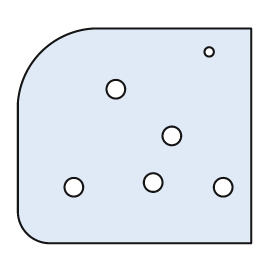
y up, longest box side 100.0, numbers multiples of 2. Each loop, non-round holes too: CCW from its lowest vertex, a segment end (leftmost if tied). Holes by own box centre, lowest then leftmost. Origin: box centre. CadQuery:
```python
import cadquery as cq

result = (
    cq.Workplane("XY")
    .moveTo(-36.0, -46.0)
    .lineTo(50.0, -46.0)
    .lineTo(50.0, 46.0)
    .lineTo(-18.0, 46.0)
    .threePointArc((-40.0, 36.0), (-50.0, 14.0))
    .lineTo(-50.0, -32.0)
    .threePointArc((-46.0, -42.0), (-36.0, -46.0))
    .close()
    .moveTo(-26.0, -22.0)
    .circle(4.0)
    .moveTo(38.0, -22.0)
    .circle(4.0)
    .moveTo(8.0, -20.0)
    .circle(4.0)
    .moveTo(16.0, 0.0)
    .circle(4.0)
    .moveTo(-8.0, 20.0)
    .circle(4.0)
    .moveTo(32.0, 36.0)
    .circle(2.0)
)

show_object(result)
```